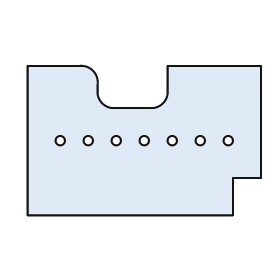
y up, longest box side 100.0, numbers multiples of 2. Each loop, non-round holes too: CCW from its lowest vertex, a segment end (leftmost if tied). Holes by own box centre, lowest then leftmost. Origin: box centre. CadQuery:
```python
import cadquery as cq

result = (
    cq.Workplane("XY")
    .moveTo(-50.0, -32.0)
    .lineTo(38.0, -32.0)
    .lineTo(38.0, -16.0)
    .lineTo(50.0, -16.0)
    .lineTo(50.0, 32.0)
    .lineTo(10.0, 32.0)
    .lineTo(10.0, 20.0)
    .threePointArc((8.0, 16.0), (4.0, 14.0))
    .lineTo(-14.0, 14.0)
    .threePointArc((-18.0, 16.0), (-20.0, 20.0))
    .lineTo(-20.0, 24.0)
    .threePointArc((-22.0, 30.0), (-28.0, 32.0))
    .lineTo(-50.0, 32.0)
    .close()
    .moveTo(-36.0, 0.0)
    .circle(2.0)
    .moveTo(-24.0, 0.0)
    .circle(2.0)
    .moveTo(-12.0, 0.0)
    .circle(2.0)
    .moveTo(0.0, 0.0)
    .circle(2.0)
    .moveTo(12.0, 0.0)
    .circle(2.0)
    .moveTo(24.0, 0.0)
    .circle(2.0)
    .moveTo(36.0, 0.0)
    .circle(2.0)
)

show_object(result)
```